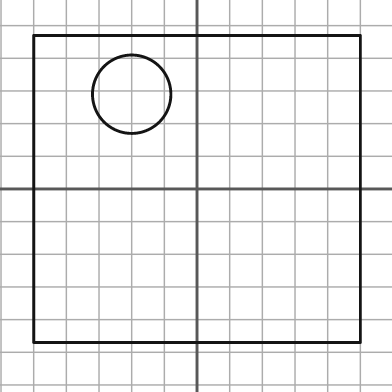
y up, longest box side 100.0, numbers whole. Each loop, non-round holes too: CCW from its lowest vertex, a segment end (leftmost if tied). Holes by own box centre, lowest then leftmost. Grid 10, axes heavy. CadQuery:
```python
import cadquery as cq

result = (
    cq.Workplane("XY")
    .moveTo(-50.0, -47.0)
    .lineTo(50.0, -47.0)
    .lineTo(50.0, 47.0)
    .lineTo(-50.0, 47.0)
    .close()
    .moveTo(-20.0, 29.0)
    .circle(12.0)
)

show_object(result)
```